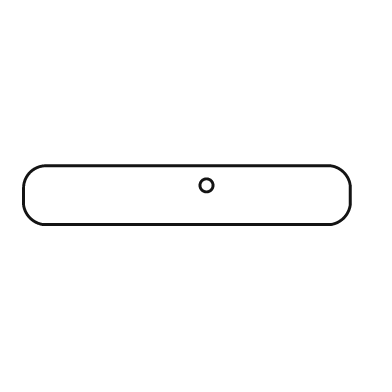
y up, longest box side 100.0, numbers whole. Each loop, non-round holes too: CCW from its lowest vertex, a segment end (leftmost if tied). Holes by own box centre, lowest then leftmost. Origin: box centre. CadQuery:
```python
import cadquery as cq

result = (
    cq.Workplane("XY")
    .moveTo(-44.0, -9.0)
    .lineTo(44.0, -9.0)
    .threePointArc((48.0, -7.0), (50.0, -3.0))
    .lineTo(50.0, 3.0)
    .threePointArc((48.0, 7.0), (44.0, 9.0))
    .lineTo(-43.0, 9.0)
    .threePointArc((-48.0, 7.0), (-50.0, 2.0))
    .lineTo(-50.0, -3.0)
    .threePointArc((-48.0, -7.0), (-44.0, -9.0))
    .close()
    .moveTo(6.0, 3.0)
    .circle(2.0)
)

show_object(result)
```